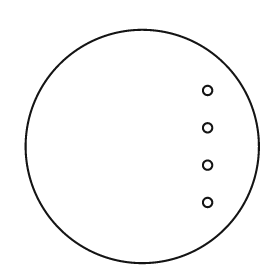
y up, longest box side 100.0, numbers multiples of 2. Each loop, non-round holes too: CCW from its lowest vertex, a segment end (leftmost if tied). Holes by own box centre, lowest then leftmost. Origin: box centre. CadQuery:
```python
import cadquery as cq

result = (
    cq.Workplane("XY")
    .moveTo(0.0, 0.0)
    .circle(50.0)
    .moveTo(28.0, -24.0)
    .circle(2.0)
    .moveTo(28.0, -8.0)
    .circle(2.0)
    .moveTo(28.0, 8.0)
    .circle(2.0)
    .moveTo(28.0, 24.0)
    .circle(2.0)
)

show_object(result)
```